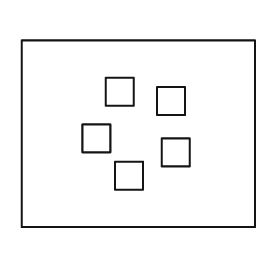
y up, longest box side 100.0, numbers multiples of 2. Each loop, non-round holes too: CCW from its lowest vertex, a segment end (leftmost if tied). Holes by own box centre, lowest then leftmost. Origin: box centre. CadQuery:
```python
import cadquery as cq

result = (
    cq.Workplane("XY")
    .moveTo(-50.0, -40.0)
    .lineTo(50.0, -40.0)
    .lineTo(50.0, 40.0)
    .lineTo(-50.0, 40.0)
    .close()
    .moveTo(-10.0, -24.0)
    .lineTo(2.0, -24.0)
    .lineTo(2.0, -12.0)
    .lineTo(-10.0, -12.0)
    .close()
    .moveTo(10.0, -14.0)
    .lineTo(22.0, -14.0)
    .lineTo(22.0, -2.0)
    .lineTo(10.0, -2.0)
    .close()
    .moveTo(-24.0, -8.0)
    .lineTo(-12.0, -8.0)
    .lineTo(-12.0, 4.0)
    .lineTo(-24.0, 4.0)
    .close()
    .moveTo(8.0, 8.0)
    .lineTo(20.0, 8.0)
    .lineTo(20.0, 20.0)
    .lineTo(8.0, 20.0)
    .close()
    .moveTo(-14.0, 12.0)
    .lineTo(-2.0, 12.0)
    .lineTo(-2.0, 24.0)
    .lineTo(-14.0, 24.0)
    .close()
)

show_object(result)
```